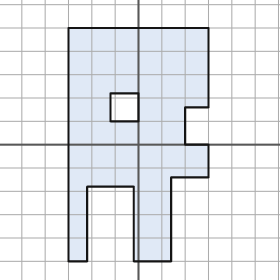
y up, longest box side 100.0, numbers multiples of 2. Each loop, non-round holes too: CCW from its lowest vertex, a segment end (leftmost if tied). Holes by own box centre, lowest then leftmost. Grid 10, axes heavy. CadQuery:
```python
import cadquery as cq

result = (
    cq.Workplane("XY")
    .moveTo(-30.0, -50.0)
    .lineTo(-22.0, -50.0)
    .lineTo(-22.0, -18.0)
    .lineTo(-2.0, -18.0)
    .lineTo(-2.0, -50.0)
    .lineTo(14.0, -50.0)
    .lineTo(14.0, -14.0)
    .lineTo(30.0, -14.0)
    .lineTo(30.0, 0.0)
    .lineTo(20.0, 0.0)
    .lineTo(20.0, 16.0)
    .lineTo(30.0, 16.0)
    .lineTo(30.0, 50.0)
    .lineTo(-30.0, 50.0)
    .close()
    .moveTo(-12.0, 10.0)
    .lineTo(0.0, 10.0)
    .lineTo(0.0, 22.0)
    .lineTo(-12.0, 22.0)
    .close()
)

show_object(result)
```